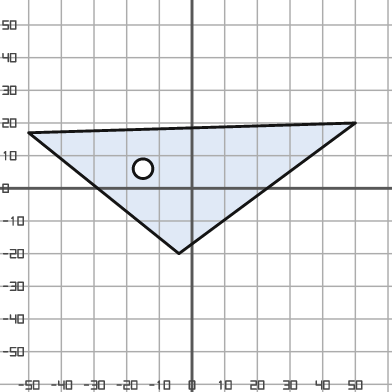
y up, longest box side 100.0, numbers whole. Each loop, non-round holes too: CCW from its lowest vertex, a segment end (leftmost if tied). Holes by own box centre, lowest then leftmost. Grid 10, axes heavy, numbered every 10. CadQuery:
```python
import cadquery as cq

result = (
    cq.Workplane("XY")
    .moveTo(-4.0, -20.0)
    .lineTo(50.0, 20.0)
    .lineTo(-50.0, 17.0)
    .close()
    .moveTo(-15.0, 6.0)
    .circle(3.0)
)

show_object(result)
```